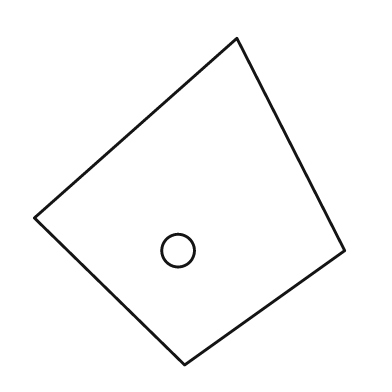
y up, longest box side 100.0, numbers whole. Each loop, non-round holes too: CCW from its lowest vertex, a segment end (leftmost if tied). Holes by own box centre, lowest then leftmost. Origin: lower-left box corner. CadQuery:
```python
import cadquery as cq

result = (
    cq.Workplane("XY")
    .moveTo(46.0, 0.0)
    .lineTo(95.0, 35.0)
    .lineTo(62.0, 100.0)
    .lineTo(0.0, 45.0)
    .close()
    .moveTo(44.0, 35.0)
    .circle(5.0)
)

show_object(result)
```